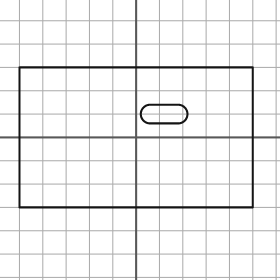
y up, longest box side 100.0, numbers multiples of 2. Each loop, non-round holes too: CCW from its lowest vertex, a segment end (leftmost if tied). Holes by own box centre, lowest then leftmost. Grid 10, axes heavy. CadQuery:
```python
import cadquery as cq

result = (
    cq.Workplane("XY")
    .moveTo(-50.0, -30.0)
    .lineTo(50.0, -30.0)
    .lineTo(50.0, 30.0)
    .lineTo(-50.0, 30.0)
    .close()
    .moveTo(6.0, 6.0)
    .lineTo(18.0, 6.0)
    .threePointArc((22.0, 10.0), (18.0, 14.0))
    .lineTo(6.0, 14.0)
    .threePointArc((2.0, 10.0), (6.0, 6.0))
    .close()
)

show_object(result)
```